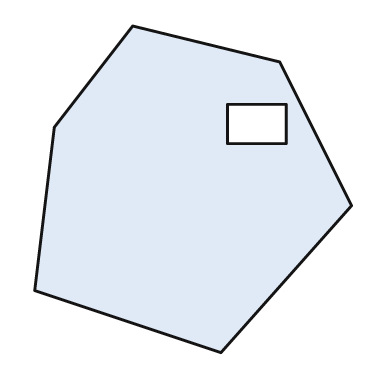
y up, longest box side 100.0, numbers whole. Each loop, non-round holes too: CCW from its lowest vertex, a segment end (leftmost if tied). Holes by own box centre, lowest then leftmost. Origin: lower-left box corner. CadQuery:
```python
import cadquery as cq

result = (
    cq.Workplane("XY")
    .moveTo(57.0, 0.0)
    .lineTo(97.0, 45.0)
    .lineTo(75.0, 89.0)
    .lineTo(30.0, 100.0)
    .lineTo(6.0, 69.0)
    .lineTo(0.0, 19.0)
    .close()
    .moveTo(59.0, 64.0)
    .lineTo(77.0, 64.0)
    .lineTo(77.0, 76.0)
    .lineTo(59.0, 76.0)
    .close()
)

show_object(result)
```